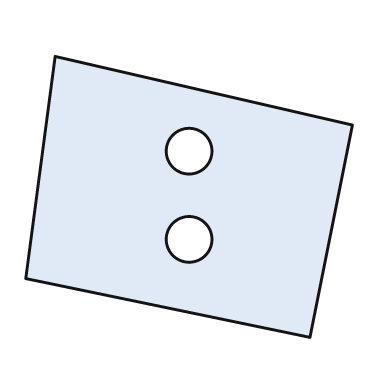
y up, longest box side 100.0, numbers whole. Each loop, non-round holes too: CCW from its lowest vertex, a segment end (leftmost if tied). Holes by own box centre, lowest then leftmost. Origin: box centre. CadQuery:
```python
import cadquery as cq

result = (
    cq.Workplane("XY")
    .moveTo(37.0, -43.0)
    .lineTo(50.0, 22.0)
    .lineTo(-41.0, 43.0)
    .lineTo(-50.0, -25.0)
    .close()
    .moveTo(0.0, -13.0)
    .circle(7.0)
    .moveTo(0.0, 14.0)
    .circle(7.0)
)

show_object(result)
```